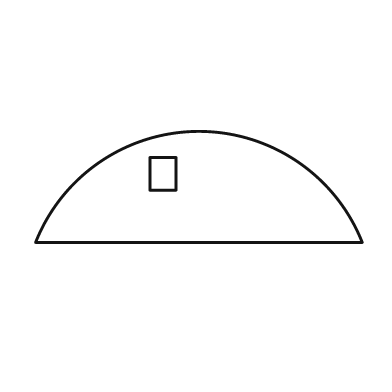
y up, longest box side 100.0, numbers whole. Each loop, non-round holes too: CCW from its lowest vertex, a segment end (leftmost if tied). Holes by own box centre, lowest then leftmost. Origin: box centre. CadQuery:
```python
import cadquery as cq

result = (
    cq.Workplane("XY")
    .moveTo(-50.0, -17.0)
    .lineTo(50.0, -17.0)
    .threePointArc((0.0, 17.0), (-50.0, -17.0))
    .close()
    .moveTo(-15.0, -1.0)
    .lineTo(-7.0, -1.0)
    .lineTo(-7.0, 9.0)
    .lineTo(-15.0, 9.0)
    .close()
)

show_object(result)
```